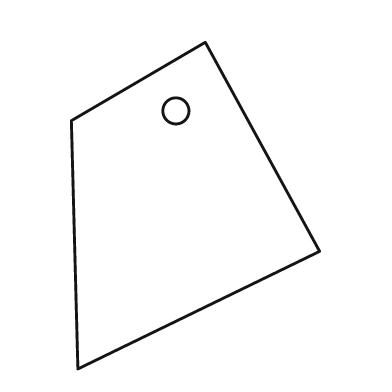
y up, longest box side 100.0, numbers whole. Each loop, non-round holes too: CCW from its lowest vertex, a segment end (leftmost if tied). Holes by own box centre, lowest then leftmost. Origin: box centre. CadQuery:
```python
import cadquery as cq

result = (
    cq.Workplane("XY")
    .moveTo(-36.0, -50.0)
    .lineTo(38.0, -14.0)
    .lineTo(3.0, 50.0)
    .lineTo(-38.0, 26.0)
    .close()
    .moveTo(-6.0, 29.0)
    .circle(4.0)
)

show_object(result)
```